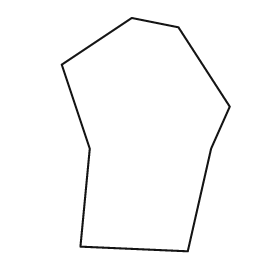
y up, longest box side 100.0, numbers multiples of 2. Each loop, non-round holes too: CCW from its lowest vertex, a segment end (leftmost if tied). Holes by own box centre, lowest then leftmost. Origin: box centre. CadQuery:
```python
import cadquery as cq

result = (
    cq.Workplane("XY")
    .moveTo(18.0, -50.0)
    .lineTo(28.0, -6.0)
    .lineTo(36.0, 12.0)
    .lineTo(14.0, 46.0)
    .lineTo(-6.0, 50.0)
    .lineTo(-36.0, 30.0)
    .lineTo(-24.0, -6.0)
    .lineTo(-28.0, -48.0)
    .close()
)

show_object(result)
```